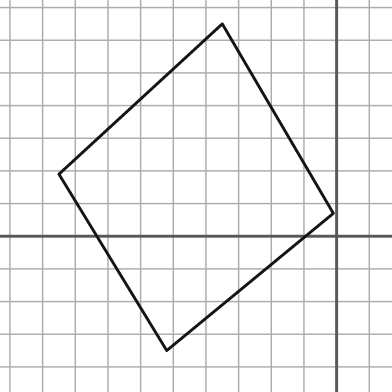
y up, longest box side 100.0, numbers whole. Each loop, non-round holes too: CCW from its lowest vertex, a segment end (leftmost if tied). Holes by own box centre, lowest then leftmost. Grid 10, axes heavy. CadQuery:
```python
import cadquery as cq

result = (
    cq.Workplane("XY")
    .moveTo(-52.0, -35.0)
    .lineTo(-1.0, 7.0)
    .lineTo(-35.0, 65.0)
    .lineTo(-85.0, 19.0)
    .close()
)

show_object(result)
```